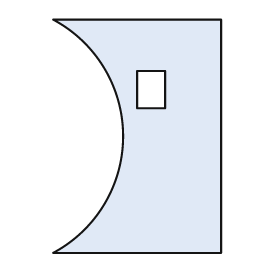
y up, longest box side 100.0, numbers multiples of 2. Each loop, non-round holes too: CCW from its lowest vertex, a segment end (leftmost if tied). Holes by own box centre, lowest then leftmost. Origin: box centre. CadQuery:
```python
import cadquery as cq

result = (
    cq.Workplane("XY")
    .moveTo(-36.0, -50.0)
    .lineTo(36.0, -50.0)
    .lineTo(36.0, 50.0)
    .lineTo(-36.0, 50.0)
    .threePointArc((-6.0, 0.0), (-36.0, -50.0))
    .close()
    .moveTo(0.0, 12.0)
    .lineTo(12.0, 12.0)
    .lineTo(12.0, 28.0)
    .lineTo(0.0, 28.0)
    .close()
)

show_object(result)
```